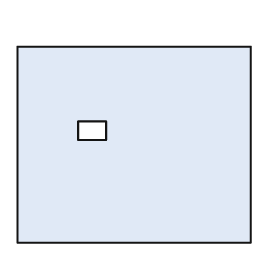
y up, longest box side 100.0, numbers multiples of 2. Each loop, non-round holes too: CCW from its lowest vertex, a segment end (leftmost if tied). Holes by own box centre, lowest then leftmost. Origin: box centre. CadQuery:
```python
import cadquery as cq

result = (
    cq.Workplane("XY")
    .moveTo(-50.0, -42.0)
    .lineTo(50.0, -42.0)
    .lineTo(50.0, 42.0)
    .lineTo(-50.0, 42.0)
    .close()
    .moveTo(-24.0, 2.0)
    .lineTo(-12.0, 2.0)
    .lineTo(-12.0, 10.0)
    .lineTo(-24.0, 10.0)
    .close()
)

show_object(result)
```